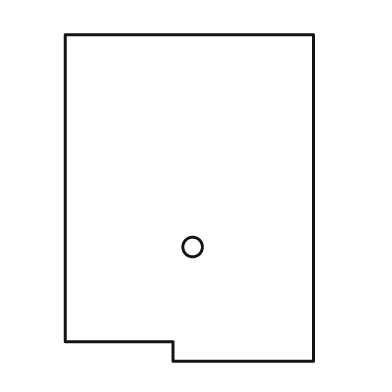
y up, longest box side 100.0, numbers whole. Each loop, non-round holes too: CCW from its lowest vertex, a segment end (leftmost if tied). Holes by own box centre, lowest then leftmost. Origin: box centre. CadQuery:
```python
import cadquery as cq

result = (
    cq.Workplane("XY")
    .moveTo(-5.0, -50.0)
    .lineTo(38.0, -50.0)
    .lineTo(38.0, 50.0)
    .lineTo(-38.0, 50.0)
    .lineTo(-38.0, -44.0)
    .lineTo(-5.0, -44.0)
    .close()
    .moveTo(1.0, -15.0)
    .circle(3.0)
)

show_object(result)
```